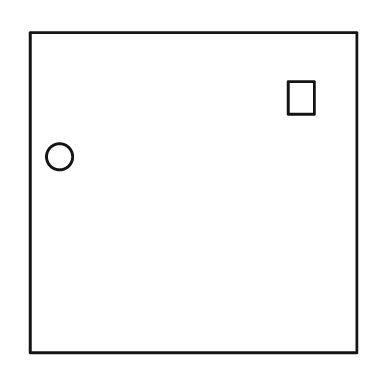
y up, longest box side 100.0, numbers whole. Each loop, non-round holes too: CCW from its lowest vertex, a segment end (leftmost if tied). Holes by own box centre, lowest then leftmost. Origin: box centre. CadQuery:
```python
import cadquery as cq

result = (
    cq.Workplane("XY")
    .moveTo(-50.0, -49.0)
    .lineTo(50.0, -49.0)
    .lineTo(50.0, 49.0)
    .lineTo(-50.0, 49.0)
    .close()
    .moveTo(-41.0, 11.0)
    .circle(4.0)
    .moveTo(29.0, 24.0)
    .lineTo(37.0, 24.0)
    .lineTo(37.0, 34.0)
    .lineTo(29.0, 34.0)
    .close()
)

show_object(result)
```